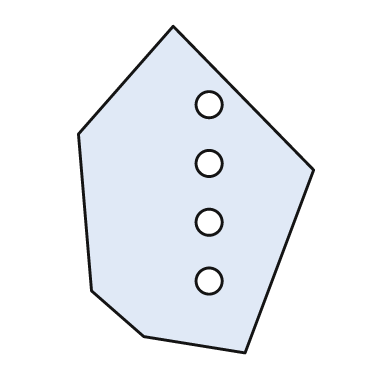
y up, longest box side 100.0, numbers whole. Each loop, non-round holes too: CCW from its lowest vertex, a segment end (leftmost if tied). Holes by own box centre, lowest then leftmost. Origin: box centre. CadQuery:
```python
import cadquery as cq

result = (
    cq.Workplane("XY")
    .moveTo(15.0, -50.0)
    .lineTo(36.0, 6.0)
    .lineTo(-7.0, 50.0)
    .lineTo(-36.0, 17.0)
    .lineTo(-32.0, -31.0)
    .lineTo(-16.0, -45.0)
    .close()
    .moveTo(4.0, -28.0)
    .circle(4.0)
    .moveTo(4.0, -10.0)
    .circle(4.0)
    .moveTo(4.0, 8.0)
    .circle(4.0)
    .moveTo(4.0, 26.0)
    .circle(4.0)
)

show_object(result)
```